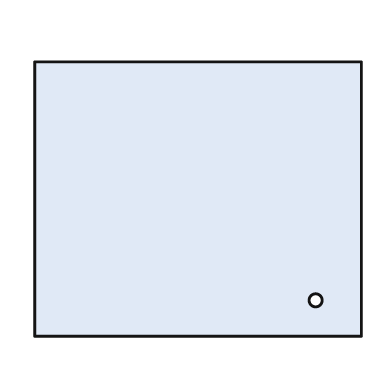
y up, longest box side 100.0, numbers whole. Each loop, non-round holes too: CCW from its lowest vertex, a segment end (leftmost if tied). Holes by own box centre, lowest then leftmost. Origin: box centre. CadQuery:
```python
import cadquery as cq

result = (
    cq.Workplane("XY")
    .moveTo(-50.0, -42.0)
    .lineTo(50.0, -42.0)
    .lineTo(50.0, 42.0)
    .lineTo(-50.0, 42.0)
    .close()
    .moveTo(36.0, -31.0)
    .circle(2.0)
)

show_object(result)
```